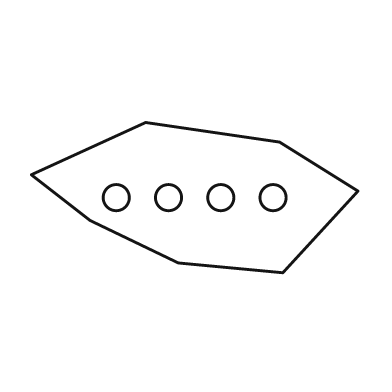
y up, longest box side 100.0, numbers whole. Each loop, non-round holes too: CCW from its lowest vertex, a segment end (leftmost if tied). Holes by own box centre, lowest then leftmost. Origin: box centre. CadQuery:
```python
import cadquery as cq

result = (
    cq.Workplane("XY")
    .moveTo(27.0, -23.0)
    .lineTo(50.0, 2.0)
    .lineTo(26.0, 17.0)
    .lineTo(-15.0, 23.0)
    .lineTo(-50.0, 7.0)
    .lineTo(-32.0, -7.0)
    .lineTo(-5.0, -20.0)
    .close()
    .moveTo(-24.0, 0.0)
    .circle(4.0)
    .moveTo(-8.0, 0.0)
    .circle(4.0)
    .moveTo(8.0, 0.0)
    .circle(4.0)
    .moveTo(24.0, 0.0)
    .circle(4.0)
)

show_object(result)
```